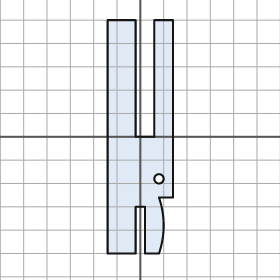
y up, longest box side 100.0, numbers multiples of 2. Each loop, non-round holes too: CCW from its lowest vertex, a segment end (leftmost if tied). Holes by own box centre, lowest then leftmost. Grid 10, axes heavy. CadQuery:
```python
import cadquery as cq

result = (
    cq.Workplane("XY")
    .moveTo(-14.0, -50.0)
    .lineTo(-2.0, -50.0)
    .lineTo(-2.0, -30.0)
    .lineTo(2.0, -30.0)
    .lineTo(2.0, -50.0)
    .lineTo(8.0, -50.0)
    .threePointArc((10.0, -38.0), (8.0, -26.0))
    .lineTo(14.0, -26.0)
    .lineTo(14.0, 50.0)
    .lineTo(6.0, 50.0)
    .lineTo(6.0, 0.0)
    .lineTo(-2.0, 0.0)
    .lineTo(-2.0, 50.0)
    .lineTo(-14.0, 50.0)
    .close()
    .moveTo(8.0, -18.0)
    .circle(2.0)
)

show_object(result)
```